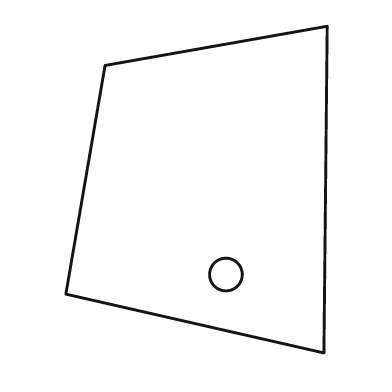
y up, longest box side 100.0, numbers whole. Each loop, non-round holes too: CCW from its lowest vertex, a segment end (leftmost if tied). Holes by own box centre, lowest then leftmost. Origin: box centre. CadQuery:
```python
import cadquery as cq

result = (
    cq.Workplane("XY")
    .moveTo(39.0, -50.0)
    .lineTo(40.0, 50.0)
    .lineTo(-28.0, 38.0)
    .lineTo(-40.0, -32.0)
    .close()
    .moveTo(9.0, -26.0)
    .circle(5.0)
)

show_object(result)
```